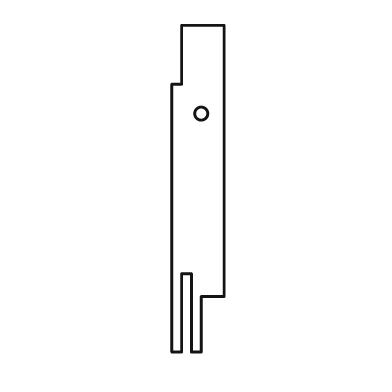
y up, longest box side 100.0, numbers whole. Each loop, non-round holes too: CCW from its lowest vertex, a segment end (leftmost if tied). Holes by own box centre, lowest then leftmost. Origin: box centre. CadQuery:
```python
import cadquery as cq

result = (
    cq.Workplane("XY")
    .moveTo(-8.0, -50.0)
    .lineTo(-5.0, -50.0)
    .lineTo(-5.0, -26.0)
    .lineTo(-2.0, -26.0)
    .lineTo(-2.0, -50.0)
    .lineTo(1.0, -50.0)
    .lineTo(1.0, -33.0)
    .lineTo(8.0, -33.0)
    .lineTo(8.0, 50.0)
    .lineTo(-5.0, 50.0)
    .lineTo(-5.0, 32.0)
    .lineTo(-8.0, 32.0)
    .close()
    .moveTo(1.0, 23.0)
    .circle(2.0)
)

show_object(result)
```